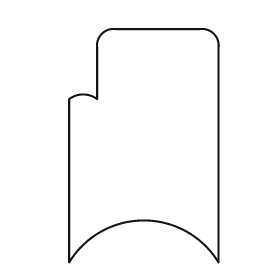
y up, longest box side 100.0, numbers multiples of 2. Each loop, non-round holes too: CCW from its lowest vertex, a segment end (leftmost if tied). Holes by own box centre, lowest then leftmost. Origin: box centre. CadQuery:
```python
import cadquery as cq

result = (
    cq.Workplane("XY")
    .moveTo(-32.0, -50.0)
    .threePointArc((0.0, -32.0), (32.0, -50.0))
    .lineTo(32.0, 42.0)
    .threePointArc((30.0, 48.0), (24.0, 50.0))
    .lineTo(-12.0, 50.0)
    .threePointArc((-18.0, 48.0), (-20.0, 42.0))
    .lineTo(-20.0, 20.0)
    .threePointArc((-26.0, 22.0), (-32.0, 20.0))
    .close()
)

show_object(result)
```